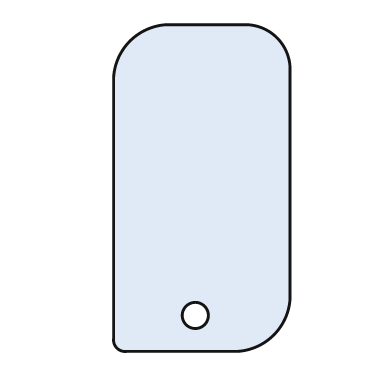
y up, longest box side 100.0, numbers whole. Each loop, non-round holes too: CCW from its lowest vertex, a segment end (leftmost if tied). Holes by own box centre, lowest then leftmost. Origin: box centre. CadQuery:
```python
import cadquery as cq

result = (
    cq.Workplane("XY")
    .moveTo(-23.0, -50.0)
    .lineTo(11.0, -50.0)
    .threePointArc((22.0, -45.0), (27.0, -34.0))
    .lineTo(27.0, 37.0)
    .threePointArc((23.0, 46.0), (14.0, 50.0))
    .lineTo(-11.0, 50.0)
    .threePointArc((-22.0, 45.0), (-27.0, 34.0))
    .lineTo(-27.0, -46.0)
    .threePointArc((-26.0, -49.0), (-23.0, -50.0))
    .close()
    .moveTo(-2.0, -39.0)
    .circle(4.0)
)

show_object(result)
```